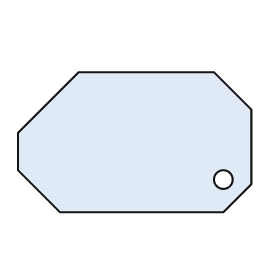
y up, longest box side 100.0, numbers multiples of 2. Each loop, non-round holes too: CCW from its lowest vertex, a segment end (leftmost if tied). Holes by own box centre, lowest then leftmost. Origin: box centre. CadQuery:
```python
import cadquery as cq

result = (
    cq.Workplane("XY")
    .moveTo(-32.0, -30.0)
    .lineTo(38.0, -30.0)
    .lineTo(50.0, -18.0)
    .lineTo(50.0, 14.0)
    .lineTo(34.0, 30.0)
    .lineTo(-24.0, 30.0)
    .lineTo(-50.0, 4.0)
    .lineTo(-50.0, -12.0)
    .close()
    .moveTo(38.0, -16.0)
    .circle(4.0)
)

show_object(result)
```